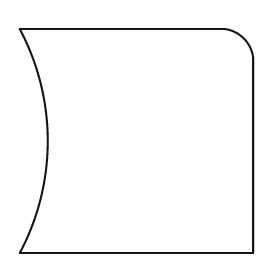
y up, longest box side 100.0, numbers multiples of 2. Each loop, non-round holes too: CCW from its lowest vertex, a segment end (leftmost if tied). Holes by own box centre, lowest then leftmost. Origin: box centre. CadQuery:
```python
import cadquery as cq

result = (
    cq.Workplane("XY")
    .moveTo(-50.0, -48.0)
    .lineTo(50.0, -48.0)
    .lineTo(50.0, 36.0)
    .threePointArc((46.0, 44.0), (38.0, 48.0))
    .lineTo(-50.0, 48.0)
    .threePointArc((-38.0, 0.0), (-50.0, -48.0))
    .close()
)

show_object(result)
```